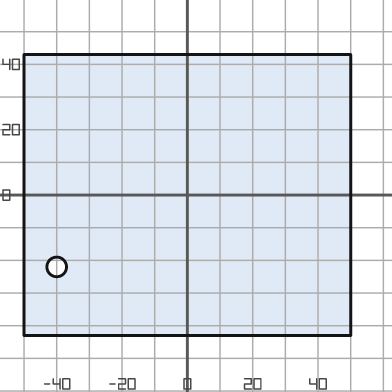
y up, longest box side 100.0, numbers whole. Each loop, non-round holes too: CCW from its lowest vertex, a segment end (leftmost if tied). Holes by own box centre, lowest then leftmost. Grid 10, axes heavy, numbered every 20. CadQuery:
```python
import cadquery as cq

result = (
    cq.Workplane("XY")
    .moveTo(-50.0, -43.0)
    .lineTo(50.0, -43.0)
    .lineTo(50.0, 43.0)
    .lineTo(-50.0, 43.0)
    .close()
    .moveTo(-40.0, -22.0)
    .circle(3.0)
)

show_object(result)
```